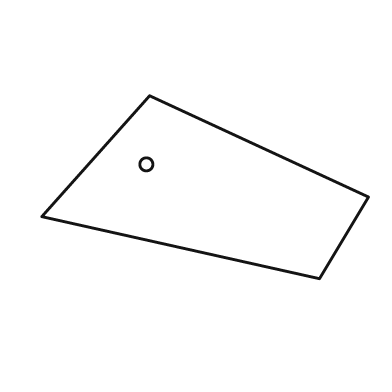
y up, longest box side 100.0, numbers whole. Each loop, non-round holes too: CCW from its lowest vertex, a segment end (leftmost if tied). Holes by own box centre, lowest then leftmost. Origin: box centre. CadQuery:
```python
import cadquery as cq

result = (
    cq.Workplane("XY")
    .moveTo(35.0, -28.0)
    .lineTo(50.0, -3.0)
    .lineTo(-17.0, 28.0)
    .lineTo(-50.0, -9.0)
    .close()
    .moveTo(-18.0, 7.0)
    .circle(2.0)
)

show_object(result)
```